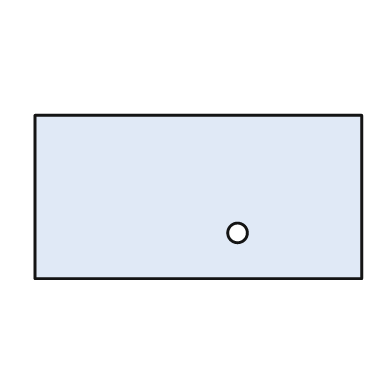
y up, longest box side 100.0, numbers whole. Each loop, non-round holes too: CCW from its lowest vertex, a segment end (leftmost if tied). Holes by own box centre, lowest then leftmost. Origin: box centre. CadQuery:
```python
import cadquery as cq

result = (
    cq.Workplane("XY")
    .moveTo(-50.0, -25.0)
    .lineTo(50.0, -25.0)
    .lineTo(50.0, 25.0)
    .lineTo(-50.0, 25.0)
    .close()
    .moveTo(12.0, -11.0)
    .circle(3.0)
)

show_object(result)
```